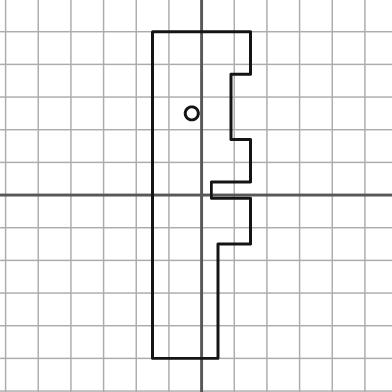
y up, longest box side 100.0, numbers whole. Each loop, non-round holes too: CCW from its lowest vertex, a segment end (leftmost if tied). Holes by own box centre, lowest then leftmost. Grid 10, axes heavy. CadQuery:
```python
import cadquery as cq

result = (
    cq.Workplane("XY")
    .moveTo(-15.0, -50.0)
    .lineTo(5.0, -50.0)
    .lineTo(5.0, -15.0)
    .lineTo(15.0, -15.0)
    .lineTo(15.0, -1.0)
    .lineTo(3.0, -1.0)
    .lineTo(3.0, 4.0)
    .lineTo(15.0, 4.0)
    .lineTo(15.0, 17.0)
    .lineTo(9.0, 17.0)
    .lineTo(9.0, 37.0)
    .lineTo(15.0, 37.0)
    .lineTo(15.0, 50.0)
    .lineTo(-15.0, 50.0)
    .close()
    .moveTo(-3.0, 25.0)
    .circle(2.0)
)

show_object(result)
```